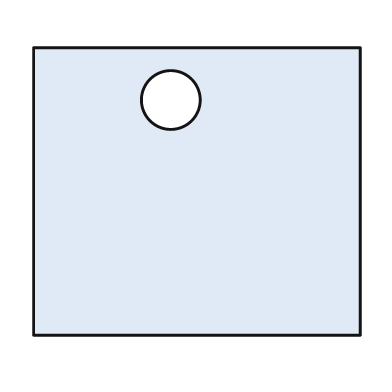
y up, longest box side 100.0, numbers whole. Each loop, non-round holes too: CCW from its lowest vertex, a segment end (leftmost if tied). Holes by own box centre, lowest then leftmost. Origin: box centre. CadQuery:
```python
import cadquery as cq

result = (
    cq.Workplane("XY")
    .moveTo(-50.0, -44.0)
    .lineTo(50.0, -44.0)
    .lineTo(50.0, 44.0)
    .lineTo(-50.0, 44.0)
    .close()
    .moveTo(-8.0, 28.0)
    .circle(9.0)
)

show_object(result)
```